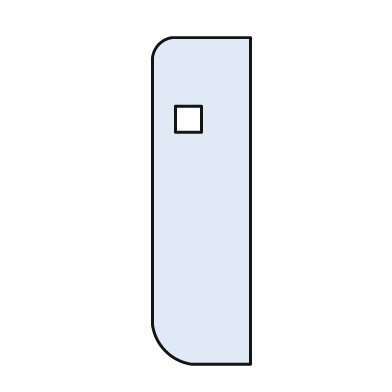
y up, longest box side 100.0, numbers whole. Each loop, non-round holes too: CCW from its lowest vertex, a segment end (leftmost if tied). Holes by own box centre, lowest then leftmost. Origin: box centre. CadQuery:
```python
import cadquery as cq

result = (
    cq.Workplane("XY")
    .moveTo(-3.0, -50.0)
    .lineTo(15.0, -50.0)
    .lineTo(15.0, 50.0)
    .lineTo(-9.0, 50.0)
    .threePointArc((-13.0, 48.0), (-15.0, 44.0))
    .lineTo(-15.0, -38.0)
    .threePointArc((-11.0, -46.0), (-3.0, -50.0))
    .close()
    .moveTo(-8.0, 21.0)
    .lineTo(0.0, 21.0)
    .lineTo(0.0, 29.0)
    .lineTo(-8.0, 29.0)
    .close()
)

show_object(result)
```